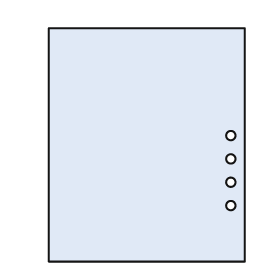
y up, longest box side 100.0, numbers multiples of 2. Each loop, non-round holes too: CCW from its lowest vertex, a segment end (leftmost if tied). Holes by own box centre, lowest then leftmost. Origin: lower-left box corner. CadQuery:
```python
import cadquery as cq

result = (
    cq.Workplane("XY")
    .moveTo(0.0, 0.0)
    .lineTo(84.0, 0.0)
    .lineTo(84.0, 100.0)
    .lineTo(0.0, 100.0)
    .close()
    .moveTo(78.0, 24.0)
    .circle(2.0)
    .moveTo(78.0, 34.0)
    .circle(2.0)
    .moveTo(78.0, 44.0)
    .circle(2.0)
    .moveTo(78.0, 54.0)
    .circle(2.0)
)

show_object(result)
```